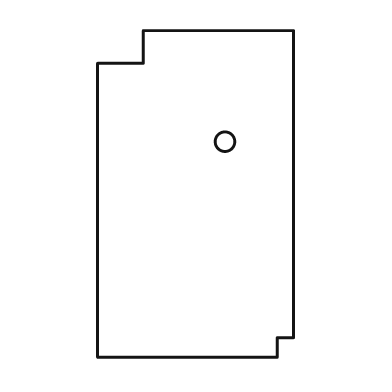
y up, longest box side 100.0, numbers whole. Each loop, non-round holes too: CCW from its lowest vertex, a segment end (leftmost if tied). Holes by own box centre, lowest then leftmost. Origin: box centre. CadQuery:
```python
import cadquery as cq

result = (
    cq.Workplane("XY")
    .moveTo(-30.0, -50.0)
    .lineTo(25.0, -50.0)
    .lineTo(25.0, -44.0)
    .lineTo(30.0, -44.0)
    .lineTo(30.0, 50.0)
    .lineTo(-16.0, 50.0)
    .lineTo(-16.0, 40.0)
    .lineTo(-30.0, 40.0)
    .close()
    .moveTo(9.0, 16.0)
    .circle(3.0)
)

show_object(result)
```